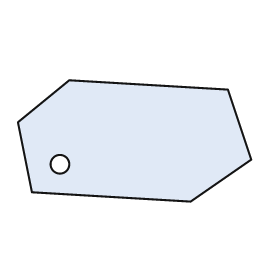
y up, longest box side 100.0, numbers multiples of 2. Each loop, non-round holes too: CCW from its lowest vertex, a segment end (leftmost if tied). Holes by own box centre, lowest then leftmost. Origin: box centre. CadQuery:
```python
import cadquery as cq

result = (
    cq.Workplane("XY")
    .moveTo(24.0, -26.0)
    .lineTo(50.0, -8.0)
    .lineTo(40.0, 22.0)
    .lineTo(-28.0, 26.0)
    .lineTo(-50.0, 8.0)
    .lineTo(-44.0, -22.0)
    .close()
    .moveTo(-32.0, -10.0)
    .circle(4.0)
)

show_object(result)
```